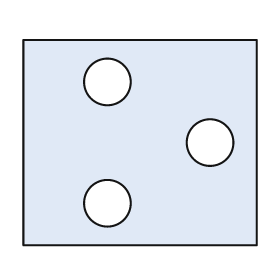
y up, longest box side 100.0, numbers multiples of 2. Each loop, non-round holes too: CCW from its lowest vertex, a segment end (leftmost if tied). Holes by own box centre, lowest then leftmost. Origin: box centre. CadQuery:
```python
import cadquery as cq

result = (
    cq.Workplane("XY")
    .moveTo(-50.0, -44.0)
    .lineTo(50.0, -44.0)
    .lineTo(50.0, 44.0)
    .lineTo(-50.0, 44.0)
    .close()
    .moveTo(-14.0, -26.0)
    .circle(10.0)
    .moveTo(30.0, 0.0)
    .circle(10.0)
    .moveTo(-14.0, 26.0)
    .circle(10.0)
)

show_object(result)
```